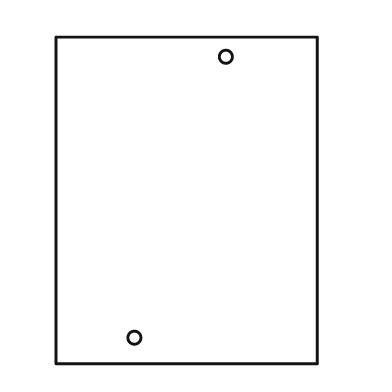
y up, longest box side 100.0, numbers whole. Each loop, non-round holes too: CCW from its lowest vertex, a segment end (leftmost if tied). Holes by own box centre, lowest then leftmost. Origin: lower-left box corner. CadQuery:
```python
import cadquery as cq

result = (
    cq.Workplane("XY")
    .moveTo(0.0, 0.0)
    .lineTo(80.0, 0.0)
    .lineTo(80.0, 100.0)
    .lineTo(0.0, 100.0)
    .close()
    .moveTo(24.0, 8.0)
    .circle(2.0)
    .moveTo(52.0, 94.0)
    .circle(2.0)
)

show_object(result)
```